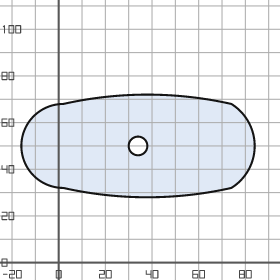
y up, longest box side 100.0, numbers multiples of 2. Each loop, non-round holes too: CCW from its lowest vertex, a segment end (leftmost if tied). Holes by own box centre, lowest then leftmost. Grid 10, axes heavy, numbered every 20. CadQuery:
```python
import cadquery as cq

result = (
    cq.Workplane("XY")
    .moveTo(2.0, 32.0)
    .threePointArc((38.0, 28.0), (74.0, 32.0))
    .threePointArc((84.0, 50.0), (74.0, 68.0))
    .threePointArc((38.0, 72.0), (2.0, 68.0))
    .threePointArc((-16.0, 50.0), (2.0, 32.0))
    .close()
    .moveTo(34.0, 50.0)
    .circle(4.0)
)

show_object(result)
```